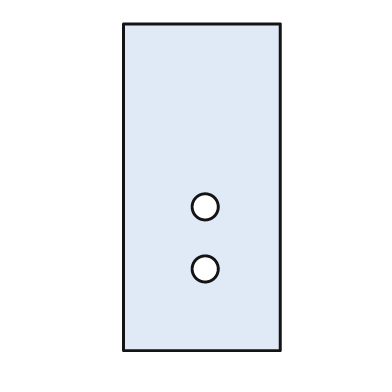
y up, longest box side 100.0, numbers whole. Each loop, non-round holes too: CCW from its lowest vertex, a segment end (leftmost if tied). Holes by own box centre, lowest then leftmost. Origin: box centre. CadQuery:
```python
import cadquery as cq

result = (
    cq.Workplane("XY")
    .moveTo(-24.0, -50.0)
    .lineTo(24.0, -50.0)
    .lineTo(24.0, 50.0)
    .lineTo(-24.0, 50.0)
    .close()
    .moveTo(1.0, -25.0)
    .circle(4.0)
    .moveTo(1.0, -6.0)
    .circle(4.0)
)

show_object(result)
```